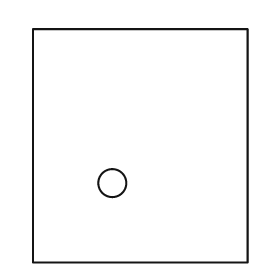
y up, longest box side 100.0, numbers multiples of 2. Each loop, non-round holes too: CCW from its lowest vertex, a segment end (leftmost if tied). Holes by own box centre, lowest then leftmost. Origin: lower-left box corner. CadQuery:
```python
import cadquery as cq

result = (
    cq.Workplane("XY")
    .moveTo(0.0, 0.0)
    .lineTo(92.0, 0.0)
    .lineTo(92.0, 100.0)
    .lineTo(0.0, 100.0)
    .close()
    .moveTo(34.0, 34.0)
    .circle(6.0)
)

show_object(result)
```